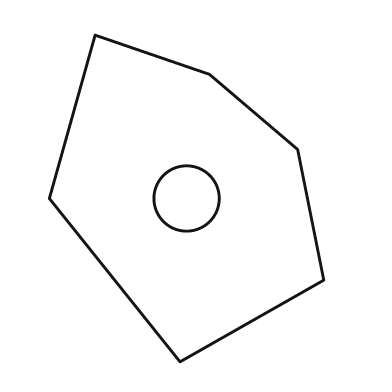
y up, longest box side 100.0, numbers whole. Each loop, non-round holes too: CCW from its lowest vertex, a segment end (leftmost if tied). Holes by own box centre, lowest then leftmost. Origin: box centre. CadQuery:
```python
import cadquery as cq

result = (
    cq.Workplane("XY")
    .moveTo(-2.0, -50.0)
    .lineTo(42.0, -25.0)
    .lineTo(34.0, 15.0)
    .lineTo(7.0, 38.0)
    .lineTo(-28.0, 50.0)
    .lineTo(-42.0, 0.0)
    .close()
    .moveTo(0.0, 0.0)
    .circle(10.0)
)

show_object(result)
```